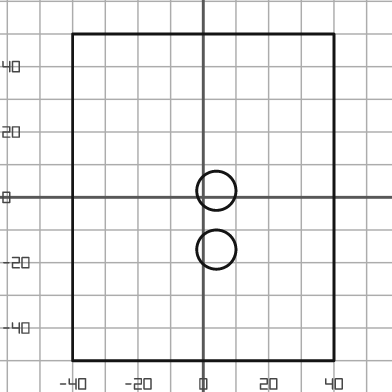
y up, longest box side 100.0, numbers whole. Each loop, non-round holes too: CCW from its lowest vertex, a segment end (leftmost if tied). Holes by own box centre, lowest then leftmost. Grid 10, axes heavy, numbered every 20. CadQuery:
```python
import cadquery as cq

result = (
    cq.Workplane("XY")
    .moveTo(-40.0, -50.0)
    .lineTo(40.0, -50.0)
    .lineTo(40.0, 50.0)
    .lineTo(-40.0, 50.0)
    .close()
    .moveTo(4.0, -16.0)
    .circle(6.0)
    .moveTo(4.0, 2.0)
    .circle(6.0)
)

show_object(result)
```